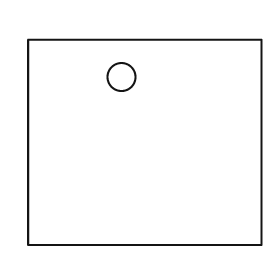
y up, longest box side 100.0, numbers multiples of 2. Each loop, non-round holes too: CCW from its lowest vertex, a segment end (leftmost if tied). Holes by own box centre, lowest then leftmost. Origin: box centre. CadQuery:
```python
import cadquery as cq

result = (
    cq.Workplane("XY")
    .moveTo(-50.0, -44.0)
    .lineTo(50.0, -44.0)
    .lineTo(50.0, 44.0)
    .lineTo(-50.0, 44.0)
    .close()
    .moveTo(-10.0, 28.0)
    .circle(6.0)
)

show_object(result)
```